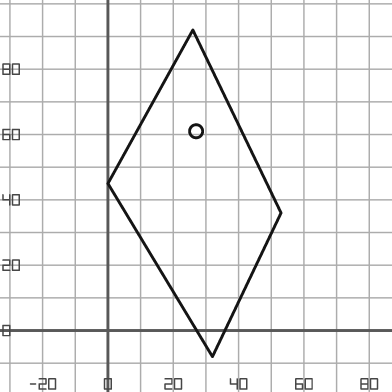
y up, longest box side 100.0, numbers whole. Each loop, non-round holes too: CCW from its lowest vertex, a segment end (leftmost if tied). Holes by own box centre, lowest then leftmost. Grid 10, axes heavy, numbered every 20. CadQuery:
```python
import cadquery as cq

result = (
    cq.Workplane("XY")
    .moveTo(32.0, -8.0)
    .lineTo(53.0, 36.0)
    .lineTo(26.0, 92.0)
    .lineTo(0.0, 45.0)
    .close()
    .moveTo(27.0, 61.0)
    .circle(2.0)
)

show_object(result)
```